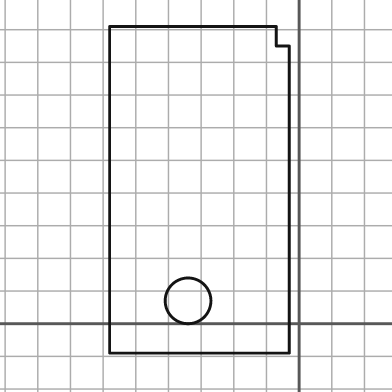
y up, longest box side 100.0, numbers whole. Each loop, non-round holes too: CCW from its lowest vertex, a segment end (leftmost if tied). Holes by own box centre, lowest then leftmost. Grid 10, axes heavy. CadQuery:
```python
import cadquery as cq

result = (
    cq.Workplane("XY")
    .moveTo(-58.0, -9.0)
    .lineTo(-3.0, -9.0)
    .lineTo(-3.0, 85.0)
    .lineTo(-7.0, 85.0)
    .lineTo(-7.0, 91.0)
    .lineTo(-58.0, 91.0)
    .close()
    .moveTo(-34.0, 7.0)
    .circle(7.0)
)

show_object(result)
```